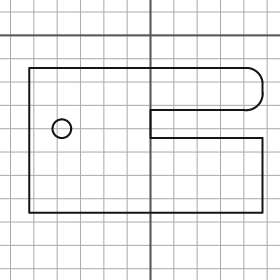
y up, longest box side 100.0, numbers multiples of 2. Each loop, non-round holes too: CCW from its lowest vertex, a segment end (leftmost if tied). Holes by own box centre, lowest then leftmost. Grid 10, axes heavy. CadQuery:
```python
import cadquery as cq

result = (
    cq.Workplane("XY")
    .moveTo(-52.0, -76.0)
    .lineTo(48.0, -76.0)
    .lineTo(48.0, -44.0)
    .lineTo(0.0, -44.0)
    .lineTo(0.0, -32.0)
    .lineTo(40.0, -32.0)
    .threePointArc((46.0, -30.0), (48.0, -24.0))
    .lineTo(48.0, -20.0)
    .threePointArc((46.0, -16.0), (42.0, -14.0))
    .lineTo(-52.0, -14.0)
    .close()
    .moveTo(-38.0, -40.0)
    .circle(4.0)
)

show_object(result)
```